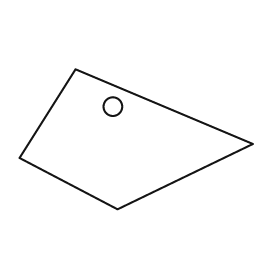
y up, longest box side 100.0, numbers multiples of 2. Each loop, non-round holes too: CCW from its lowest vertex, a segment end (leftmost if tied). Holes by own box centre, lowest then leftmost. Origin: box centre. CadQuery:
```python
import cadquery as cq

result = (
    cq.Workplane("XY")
    .moveTo(-8.0, -30.0)
    .lineTo(50.0, -2.0)
    .lineTo(-26.0, 30.0)
    .lineTo(-50.0, -8.0)
    .close()
    .moveTo(-10.0, 14.0)
    .circle(4.0)
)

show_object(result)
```